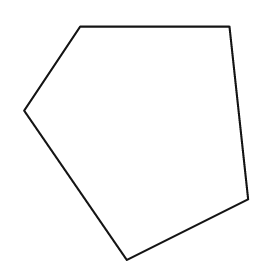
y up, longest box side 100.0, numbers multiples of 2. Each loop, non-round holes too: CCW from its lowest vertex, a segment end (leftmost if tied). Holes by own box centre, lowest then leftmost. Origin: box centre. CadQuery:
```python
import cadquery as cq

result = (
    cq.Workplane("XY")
    .moveTo(-4.0, -50.0)
    .lineTo(48.0, -24.0)
    .lineTo(40.0, 50.0)
    .lineTo(-24.0, 50.0)
    .lineTo(-48.0, 14.0)
    .close()
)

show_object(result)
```